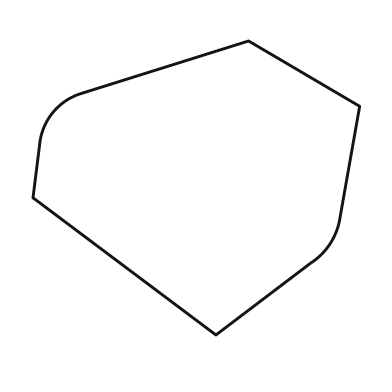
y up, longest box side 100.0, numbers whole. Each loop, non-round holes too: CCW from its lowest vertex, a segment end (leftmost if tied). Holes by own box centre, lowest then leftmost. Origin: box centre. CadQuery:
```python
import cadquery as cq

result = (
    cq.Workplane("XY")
    .moveTo(6.0, -45.0)
    .lineTo(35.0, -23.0)
    .threePointArc((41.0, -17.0), (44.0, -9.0))
    .lineTo(50.0, 25.0)
    .lineTo(16.0, 45.0)
    .lineTo(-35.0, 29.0)
    .threePointArc((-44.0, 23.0), (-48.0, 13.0))
    .lineTo(-50.0, -3.0)
    .close()
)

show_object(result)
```